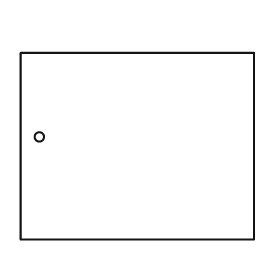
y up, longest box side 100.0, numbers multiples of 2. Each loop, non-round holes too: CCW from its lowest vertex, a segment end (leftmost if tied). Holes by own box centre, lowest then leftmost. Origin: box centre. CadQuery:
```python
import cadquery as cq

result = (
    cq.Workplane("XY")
    .moveTo(-50.0, -40.0)
    .lineTo(50.0, -40.0)
    .lineTo(50.0, 40.0)
    .lineTo(-50.0, 40.0)
    .close()
    .moveTo(-42.0, 4.0)
    .circle(2.0)
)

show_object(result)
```